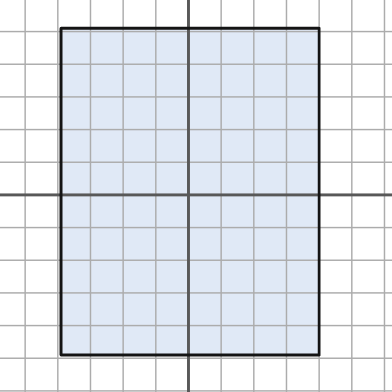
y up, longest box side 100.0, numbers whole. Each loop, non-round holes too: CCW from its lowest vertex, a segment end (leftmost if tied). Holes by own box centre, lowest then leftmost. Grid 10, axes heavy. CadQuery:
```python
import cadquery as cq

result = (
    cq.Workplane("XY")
    .moveTo(-39.0, -49.0)
    .lineTo(40.0, -49.0)
    .lineTo(40.0, 51.0)
    .lineTo(-39.0, 51.0)
    .close()
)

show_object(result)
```